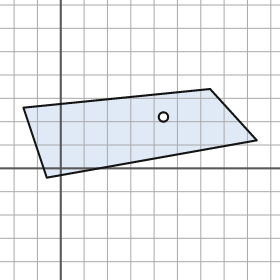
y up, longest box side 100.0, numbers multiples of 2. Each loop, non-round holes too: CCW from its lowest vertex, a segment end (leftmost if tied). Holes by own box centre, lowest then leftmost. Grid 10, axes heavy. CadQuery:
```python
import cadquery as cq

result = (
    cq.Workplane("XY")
    .moveTo(-6.0, -4.0)
    .lineTo(84.0, 12.0)
    .lineTo(64.0, 34.0)
    .lineTo(-16.0, 26.0)
    .close()
    .moveTo(44.0, 22.0)
    .circle(2.0)
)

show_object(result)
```